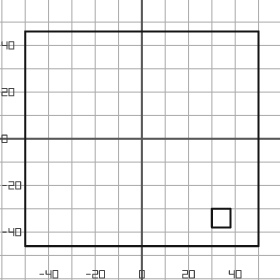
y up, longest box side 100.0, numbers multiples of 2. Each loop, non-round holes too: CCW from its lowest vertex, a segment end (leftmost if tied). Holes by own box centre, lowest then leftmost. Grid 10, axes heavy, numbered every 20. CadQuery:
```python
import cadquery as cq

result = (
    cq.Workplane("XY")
    .moveTo(-50.0, -46.0)
    .lineTo(50.0, -46.0)
    .lineTo(50.0, 46.0)
    .lineTo(-50.0, 46.0)
    .close()
    .moveTo(30.0, -38.0)
    .lineTo(38.0, -38.0)
    .lineTo(38.0, -30.0)
    .lineTo(30.0, -30.0)
    .close()
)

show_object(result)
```